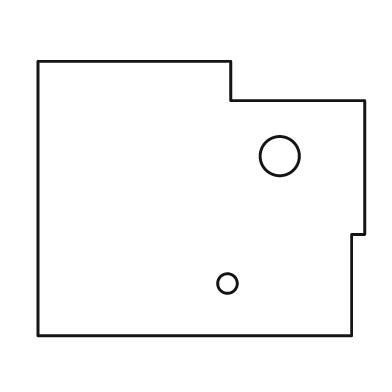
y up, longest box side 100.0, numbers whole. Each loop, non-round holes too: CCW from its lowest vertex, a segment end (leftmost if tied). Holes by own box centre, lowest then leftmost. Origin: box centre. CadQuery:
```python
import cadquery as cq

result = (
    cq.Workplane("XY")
    .moveTo(-50.0, -42.0)
    .lineTo(46.0, -42.0)
    .lineTo(46.0, -11.0)
    .lineTo(50.0, -11.0)
    .lineTo(50.0, 30.0)
    .lineTo(9.0, 30.0)
    .lineTo(9.0, 42.0)
    .lineTo(-50.0, 42.0)
    .close()
    .moveTo(8.0, -26.0)
    .circle(3.0)
    .moveTo(24.0, 13.0)
    .circle(6.0)
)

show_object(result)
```